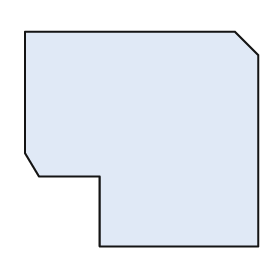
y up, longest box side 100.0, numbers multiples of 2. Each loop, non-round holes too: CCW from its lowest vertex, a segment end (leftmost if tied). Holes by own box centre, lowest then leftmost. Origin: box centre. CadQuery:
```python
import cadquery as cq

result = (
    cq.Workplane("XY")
    .moveTo(-18.0, -46.0)
    .lineTo(50.0, -46.0)
    .lineTo(50.0, 36.0)
    .lineTo(40.0, 46.0)
    .lineTo(-50.0, 46.0)
    .lineTo(-50.0, -6.0)
    .lineTo(-44.0, -16.0)
    .lineTo(-18.0, -16.0)
    .close()
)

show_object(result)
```